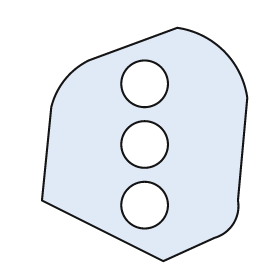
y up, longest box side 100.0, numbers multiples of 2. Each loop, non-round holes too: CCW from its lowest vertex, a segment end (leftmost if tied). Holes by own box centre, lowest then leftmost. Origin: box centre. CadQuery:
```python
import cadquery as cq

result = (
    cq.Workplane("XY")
    .moveTo(8.0, -50.0)
    .lineTo(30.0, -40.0)
    .threePointArc((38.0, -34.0), (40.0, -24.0))
    .lineTo(44.0, 20.0)
    .threePointArc((34.0, 40.0), (14.0, 50.0))
    .lineTo(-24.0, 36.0)
    .threePointArc((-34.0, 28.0), (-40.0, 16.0))
    .lineTo(-44.0, -24.0)
    .close()
    .moveTo(0.0, -26.0)
    .circle(10.0)
    .moveTo(0.0, 0.0)
    .circle(10.0)
    .moveTo(0.0, 26.0)
    .circle(10.0)
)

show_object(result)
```